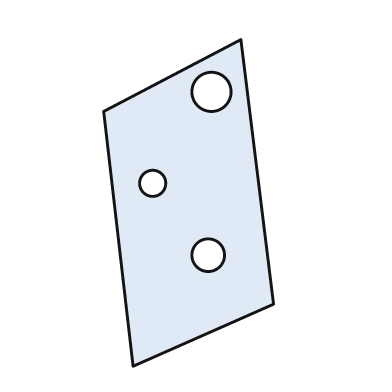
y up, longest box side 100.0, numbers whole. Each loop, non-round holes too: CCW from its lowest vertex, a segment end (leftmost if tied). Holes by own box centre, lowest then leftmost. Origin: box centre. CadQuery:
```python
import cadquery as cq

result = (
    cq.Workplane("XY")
    .moveTo(-17.0, -50.0)
    .lineTo(26.0, -31.0)
    .lineTo(16.0, 50.0)
    .lineTo(-26.0, 28.0)
    .close()
    .moveTo(6.0, -16.0)
    .circle(5.0)
    .moveTo(-11.0, 6.0)
    .circle(4.0)
    .moveTo(7.0, 34.0)
    .circle(6.0)
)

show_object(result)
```